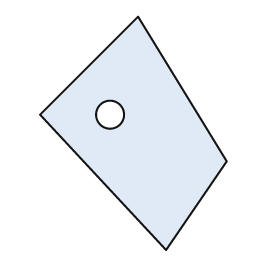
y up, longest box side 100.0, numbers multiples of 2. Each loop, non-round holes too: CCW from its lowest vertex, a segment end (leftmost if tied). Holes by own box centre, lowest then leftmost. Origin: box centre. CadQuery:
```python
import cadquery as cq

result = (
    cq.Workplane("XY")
    .moveTo(14.0, -50.0)
    .lineTo(40.0, -12.0)
    .lineTo(2.0, 50.0)
    .lineTo(-40.0, 8.0)
    .close()
    .moveTo(-10.0, 8.0)
    .circle(6.0)
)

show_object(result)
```